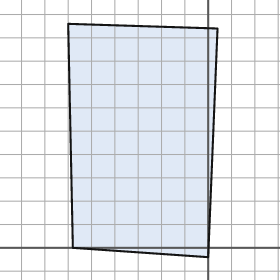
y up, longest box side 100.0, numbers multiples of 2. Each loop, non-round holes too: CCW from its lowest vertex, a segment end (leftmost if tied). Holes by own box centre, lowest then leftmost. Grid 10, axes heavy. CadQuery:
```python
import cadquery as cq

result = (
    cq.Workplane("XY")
    .moveTo(0.0, -4.0)
    .lineTo(4.0, 94.0)
    .lineTo(-60.0, 96.0)
    .lineTo(-58.0, 0.0)
    .close()
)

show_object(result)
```